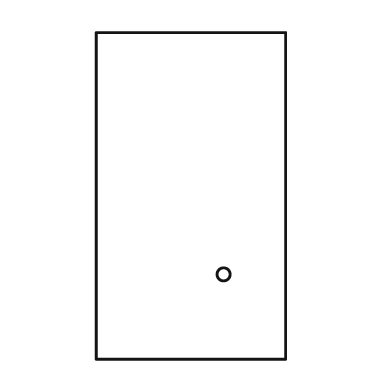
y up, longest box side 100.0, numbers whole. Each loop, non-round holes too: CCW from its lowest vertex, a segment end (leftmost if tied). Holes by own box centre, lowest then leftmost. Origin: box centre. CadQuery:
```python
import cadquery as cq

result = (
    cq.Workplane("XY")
    .moveTo(-29.0, -50.0)
    .lineTo(29.0, -50.0)
    .lineTo(29.0, 50.0)
    .lineTo(-29.0, 50.0)
    .close()
    .moveTo(10.0, -24.0)
    .circle(2.0)
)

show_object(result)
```